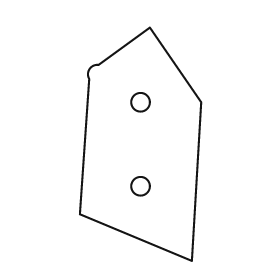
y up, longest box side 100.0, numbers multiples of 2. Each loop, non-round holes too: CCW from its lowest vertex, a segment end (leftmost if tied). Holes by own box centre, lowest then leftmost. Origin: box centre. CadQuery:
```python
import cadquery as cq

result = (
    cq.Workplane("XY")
    .moveTo(22.0, -50.0)
    .lineTo(26.0, 18.0)
    .lineTo(4.0, 50.0)
    .lineTo(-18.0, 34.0)
    .threePointArc((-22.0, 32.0), (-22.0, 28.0))
    .lineTo(-26.0, -30.0)
    .close()
    .moveTo(0.0, -18.0)
    .circle(4.0)
    .moveTo(0.0, 18.0)
    .circle(4.0)
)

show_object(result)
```